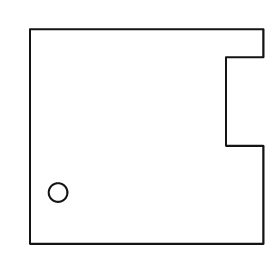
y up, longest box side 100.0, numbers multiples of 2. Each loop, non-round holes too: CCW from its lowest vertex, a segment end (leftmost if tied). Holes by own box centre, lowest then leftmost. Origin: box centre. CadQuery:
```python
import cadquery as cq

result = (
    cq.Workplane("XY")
    .moveTo(-50.0, -46.0)
    .lineTo(50.0, -46.0)
    .lineTo(50.0, -4.0)
    .lineTo(34.0, -4.0)
    .lineTo(34.0, 34.0)
    .lineTo(50.0, 34.0)
    .lineTo(50.0, 46.0)
    .lineTo(-50.0, 46.0)
    .close()
    .moveTo(-38.0, -24.0)
    .circle(4.0)
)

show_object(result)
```